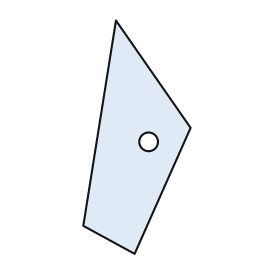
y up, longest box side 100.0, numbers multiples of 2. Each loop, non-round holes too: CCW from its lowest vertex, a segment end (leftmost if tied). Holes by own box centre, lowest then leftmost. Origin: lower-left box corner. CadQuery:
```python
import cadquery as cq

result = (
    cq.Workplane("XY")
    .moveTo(22.0, 0.0)
    .lineTo(46.0, 54.0)
    .lineTo(14.0, 100.0)
    .lineTo(0.0, 12.0)
    .close()
    .moveTo(28.0, 48.0)
    .circle(4.0)
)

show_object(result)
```